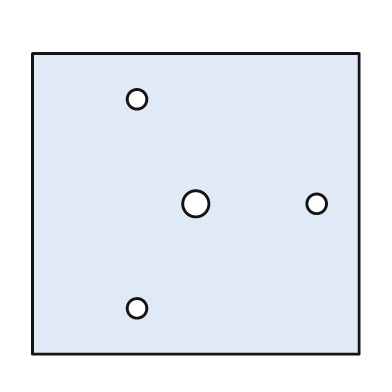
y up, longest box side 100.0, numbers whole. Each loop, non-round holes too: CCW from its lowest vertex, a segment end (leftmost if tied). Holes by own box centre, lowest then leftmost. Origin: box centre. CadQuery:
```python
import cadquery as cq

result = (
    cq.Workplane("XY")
    .moveTo(-50.0, -46.0)
    .lineTo(50.0, -46.0)
    .lineTo(50.0, 46.0)
    .lineTo(-50.0, 46.0)
    .close()
    .moveTo(-18.0, -32.0)
    .circle(3.0)
    .moveTo(0.0, 0.0)
    .circle(4.0)
    .moveTo(37.0, 0.0)
    .circle(3.0)
    .moveTo(-18.0, 32.0)
    .circle(3.0)
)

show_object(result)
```